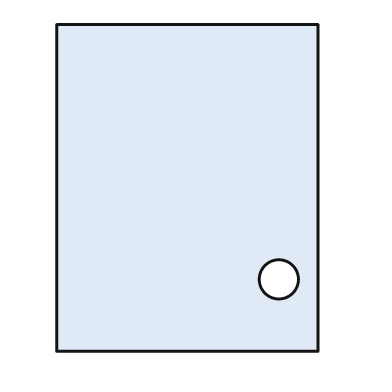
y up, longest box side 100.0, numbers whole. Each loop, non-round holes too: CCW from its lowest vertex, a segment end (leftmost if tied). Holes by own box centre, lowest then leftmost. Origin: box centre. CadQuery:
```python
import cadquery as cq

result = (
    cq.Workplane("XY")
    .moveTo(-40.0, -50.0)
    .lineTo(40.0, -50.0)
    .lineTo(40.0, 50.0)
    .lineTo(-40.0, 50.0)
    .close()
    .moveTo(28.0, -28.0)
    .circle(6.0)
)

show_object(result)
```